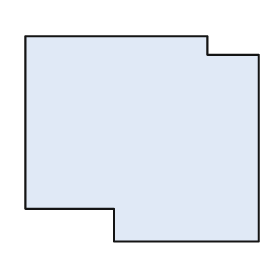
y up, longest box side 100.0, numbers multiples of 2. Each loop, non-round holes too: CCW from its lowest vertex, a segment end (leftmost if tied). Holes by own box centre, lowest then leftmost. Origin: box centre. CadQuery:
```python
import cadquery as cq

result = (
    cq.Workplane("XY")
    .moveTo(-12.0, -44.0)
    .lineTo(50.0, -44.0)
    .lineTo(50.0, 36.0)
    .lineTo(28.0, 36.0)
    .lineTo(28.0, 44.0)
    .lineTo(-50.0, 44.0)
    .lineTo(-50.0, -30.0)
    .lineTo(-12.0, -30.0)
    .close()
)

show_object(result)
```